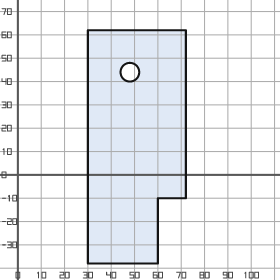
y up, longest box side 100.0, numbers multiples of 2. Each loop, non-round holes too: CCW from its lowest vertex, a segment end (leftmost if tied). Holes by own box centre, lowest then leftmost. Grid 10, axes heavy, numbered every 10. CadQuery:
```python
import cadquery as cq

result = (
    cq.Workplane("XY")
    .moveTo(30.0, -38.0)
    .lineTo(60.0, -38.0)
    .lineTo(60.0, -10.0)
    .lineTo(72.0, -10.0)
    .lineTo(72.0, 62.0)
    .lineTo(30.0, 62.0)
    .close()
    .moveTo(48.0, 44.0)
    .circle(4.0)
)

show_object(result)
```